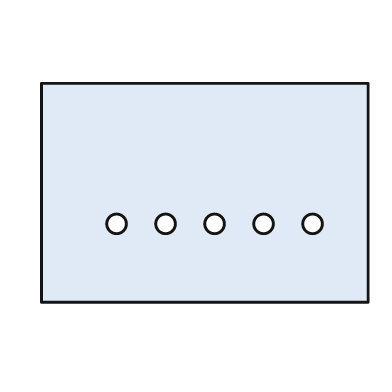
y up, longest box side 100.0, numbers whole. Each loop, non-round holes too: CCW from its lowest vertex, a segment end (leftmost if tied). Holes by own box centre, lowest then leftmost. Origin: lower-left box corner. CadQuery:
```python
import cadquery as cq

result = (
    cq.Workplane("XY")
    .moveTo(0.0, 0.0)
    .lineTo(100.0, 0.0)
    .lineTo(100.0, 67.0)
    .lineTo(0.0, 67.0)
    .close()
    .moveTo(23.0, 24.0)
    .circle(3.0)
    .moveTo(38.0, 24.0)
    .circle(3.0)
    .moveTo(53.0, 24.0)
    .circle(3.0)
    .moveTo(68.0, 24.0)
    .circle(3.0)
    .moveTo(83.0, 24.0)
    .circle(3.0)
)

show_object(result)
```